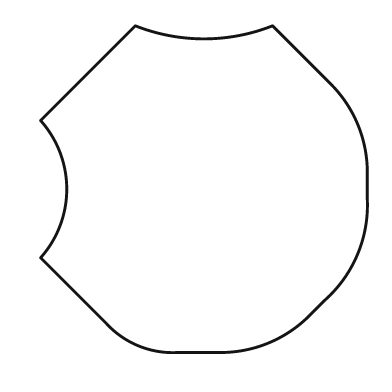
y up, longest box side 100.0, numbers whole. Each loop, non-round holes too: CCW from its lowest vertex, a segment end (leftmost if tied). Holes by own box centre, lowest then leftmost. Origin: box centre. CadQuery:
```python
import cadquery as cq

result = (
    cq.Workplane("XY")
    .moveTo(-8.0, -50.0)
    .lineTo(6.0, -50.0)
    .threePointArc((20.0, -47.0), (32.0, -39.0))
    .lineTo(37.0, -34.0)
    .threePointArc((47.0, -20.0), (50.0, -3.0))
    .lineTo(50.0, 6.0)
    .threePointArc((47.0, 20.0), (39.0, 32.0))
    .lineTo(21.0, 50.0)
    .threePointArc((0.0, 46.0), (-21.0, 50.0))
    .lineTo(-50.0, 21.0)
    .threePointArc((-42.0, 0.0), (-50.0, -21.0))
    .lineTo(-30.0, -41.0)
    .threePointArc((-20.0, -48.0), (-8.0, -50.0))
    .close()
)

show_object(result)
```